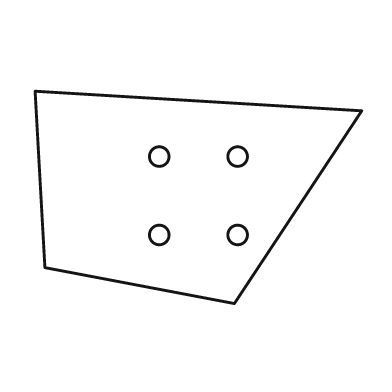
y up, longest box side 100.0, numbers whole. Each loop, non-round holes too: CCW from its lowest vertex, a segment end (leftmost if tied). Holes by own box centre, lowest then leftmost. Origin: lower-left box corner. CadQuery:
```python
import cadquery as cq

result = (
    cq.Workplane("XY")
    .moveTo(61.0, 0.0)
    .lineTo(100.0, 59.0)
    .lineTo(0.0, 65.0)
    .lineTo(3.0, 11.0)
    .close()
    .moveTo(38.0, 21.0)
    .circle(3.0)
    .moveTo(62.0, 21.0)
    .circle(3.0)
    .moveTo(38.0, 45.0)
    .circle(3.0)
    .moveTo(62.0, 45.0)
    .circle(3.0)
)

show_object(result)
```